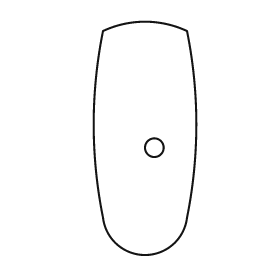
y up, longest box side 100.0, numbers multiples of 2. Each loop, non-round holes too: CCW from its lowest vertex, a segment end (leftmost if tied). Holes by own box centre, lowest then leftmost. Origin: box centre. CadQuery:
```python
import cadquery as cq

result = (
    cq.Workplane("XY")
    .moveTo(-18.0, -34.0)
    .threePointArc((0.0, -50.0), (18.0, -34.0))
    .threePointArc((22.0, 6.0), (18.0, 46.0))
    .threePointArc((0.0, 50.0), (-18.0, 46.0))
    .threePointArc((-22.0, 6.0), (-18.0, -34.0))
    .close()
    .moveTo(4.0, -4.0)
    .circle(4.0)
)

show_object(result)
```